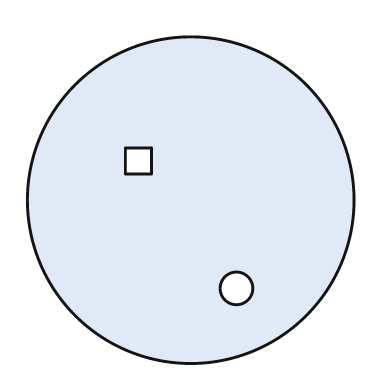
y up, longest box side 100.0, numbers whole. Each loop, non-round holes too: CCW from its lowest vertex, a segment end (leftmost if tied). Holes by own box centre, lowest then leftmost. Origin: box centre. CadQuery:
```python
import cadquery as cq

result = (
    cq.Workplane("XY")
    .moveTo(0.0, 0.0)
    .circle(50.0)
    .moveTo(14.0, -27.0)
    .circle(5.0)
    .moveTo(-20.0, 8.0)
    .lineTo(-12.0, 8.0)
    .lineTo(-12.0, 16.0)
    .lineTo(-20.0, 16.0)
    .close()
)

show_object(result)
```